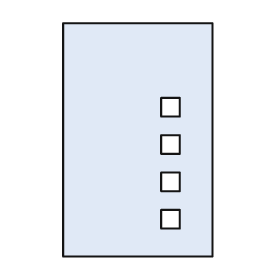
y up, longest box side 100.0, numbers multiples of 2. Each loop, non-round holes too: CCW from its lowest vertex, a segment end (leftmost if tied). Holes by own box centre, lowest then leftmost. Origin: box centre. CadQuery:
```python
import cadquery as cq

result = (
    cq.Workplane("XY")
    .moveTo(-32.0, -50.0)
    .lineTo(32.0, -50.0)
    .lineTo(32.0, 50.0)
    .lineTo(-32.0, 50.0)
    .close()
    .moveTo(10.0, -38.0)
    .lineTo(18.0, -38.0)
    .lineTo(18.0, -30.0)
    .lineTo(10.0, -30.0)
    .close()
    .moveTo(10.0, -22.0)
    .lineTo(18.0, -22.0)
    .lineTo(18.0, -14.0)
    .lineTo(10.0, -14.0)
    .close()
    .moveTo(10.0, -6.0)
    .lineTo(18.0, -6.0)
    .lineTo(18.0, 2.0)
    .lineTo(10.0, 2.0)
    .close()
    .moveTo(10.0, 10.0)
    .lineTo(18.0, 10.0)
    .lineTo(18.0, 18.0)
    .lineTo(10.0, 18.0)
    .close()
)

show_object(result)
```